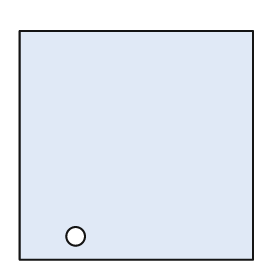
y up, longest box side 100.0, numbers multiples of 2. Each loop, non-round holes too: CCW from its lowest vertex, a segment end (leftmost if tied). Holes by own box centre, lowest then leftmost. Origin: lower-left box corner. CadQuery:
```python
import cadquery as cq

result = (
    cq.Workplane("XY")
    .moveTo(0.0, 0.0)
    .lineTo(100.0, 0.0)
    .lineTo(100.0, 98.0)
    .lineTo(0.0, 98.0)
    .close()
    .moveTo(24.0, 10.0)
    .circle(4.0)
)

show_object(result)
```